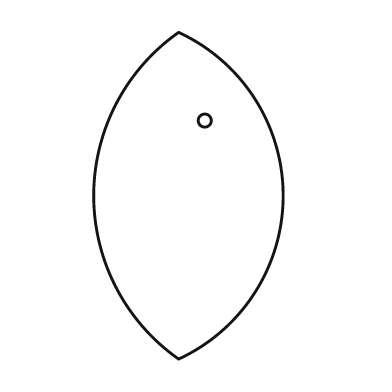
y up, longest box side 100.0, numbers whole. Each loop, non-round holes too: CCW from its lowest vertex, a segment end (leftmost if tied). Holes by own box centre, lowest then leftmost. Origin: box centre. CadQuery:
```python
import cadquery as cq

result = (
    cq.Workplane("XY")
    .moveTo(-3.0, -50.0)
    .threePointArc((29.0, 0.0), (-3.0, 50.0))
    .threePointArc((-29.0, 0.0), (-3.0, -50.0))
    .close()
    .moveTo(5.0, 23.0)
    .circle(2.0)
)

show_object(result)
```